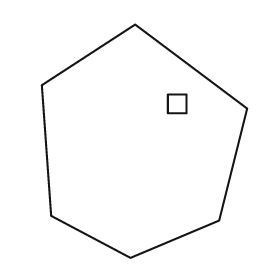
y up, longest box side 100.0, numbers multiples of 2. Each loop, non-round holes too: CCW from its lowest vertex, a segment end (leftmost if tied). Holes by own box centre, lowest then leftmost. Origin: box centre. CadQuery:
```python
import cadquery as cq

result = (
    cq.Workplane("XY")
    .moveTo(-6.0, -50.0)
    .lineTo(32.0, -34.0)
    .lineTo(44.0, 14.0)
    .lineTo(-4.0, 50.0)
    .lineTo(-44.0, 24.0)
    .lineTo(-40.0, -32.0)
    .close()
    .moveTo(10.0, 12.0)
    .lineTo(18.0, 12.0)
    .lineTo(18.0, 20.0)
    .lineTo(10.0, 20.0)
    .close()
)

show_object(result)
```